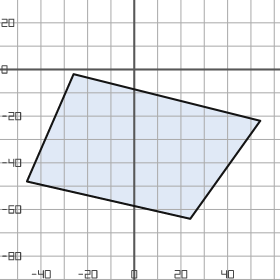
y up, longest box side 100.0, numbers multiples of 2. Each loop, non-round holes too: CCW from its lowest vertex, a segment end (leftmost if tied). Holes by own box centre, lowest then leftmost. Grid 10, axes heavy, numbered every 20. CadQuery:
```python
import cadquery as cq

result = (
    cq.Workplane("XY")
    .moveTo(24.0, -64.0)
    .lineTo(54.0, -22.0)
    .lineTo(-26.0, -2.0)
    .lineTo(-46.0, -48.0)
    .close()
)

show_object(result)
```